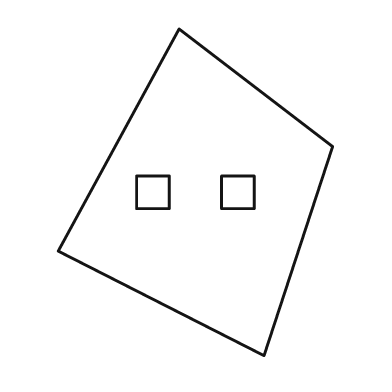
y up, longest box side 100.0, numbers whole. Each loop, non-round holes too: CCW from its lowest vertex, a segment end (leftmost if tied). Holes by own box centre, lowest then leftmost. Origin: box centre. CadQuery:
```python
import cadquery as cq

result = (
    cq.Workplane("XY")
    .moveTo(21.0, -50.0)
    .lineTo(42.0, 14.0)
    .lineTo(-5.0, 50.0)
    .lineTo(-42.0, -18.0)
    .close()
    .moveTo(-18.0, -5.0)
    .lineTo(-8.0, -5.0)
    .lineTo(-8.0, 5.0)
    .lineTo(-18.0, 5.0)
    .close()
    .moveTo(8.0, -5.0)
    .lineTo(18.0, -5.0)
    .lineTo(18.0, 5.0)
    .lineTo(8.0, 5.0)
    .close()
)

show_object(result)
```